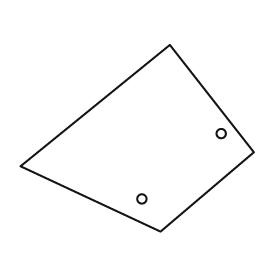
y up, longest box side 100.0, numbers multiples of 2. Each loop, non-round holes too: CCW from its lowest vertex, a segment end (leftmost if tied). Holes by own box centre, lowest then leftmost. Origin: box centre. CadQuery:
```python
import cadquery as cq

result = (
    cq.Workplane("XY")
    .moveTo(10.0, -40.0)
    .lineTo(50.0, -6.0)
    .lineTo(14.0, 40.0)
    .lineTo(-50.0, -12.0)
    .close()
    .moveTo(2.0, -26.0)
    .circle(2.0)
    .moveTo(36.0, 2.0)
    .circle(2.0)
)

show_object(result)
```